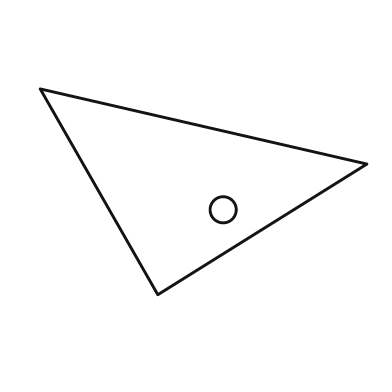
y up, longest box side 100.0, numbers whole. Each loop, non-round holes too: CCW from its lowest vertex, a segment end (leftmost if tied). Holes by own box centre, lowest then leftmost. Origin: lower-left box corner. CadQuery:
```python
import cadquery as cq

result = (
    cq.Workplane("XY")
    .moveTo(36.0, 0.0)
    .lineTo(100.0, 40.0)
    .lineTo(0.0, 63.0)
    .close()
    .moveTo(56.0, 26.0)
    .circle(4.0)
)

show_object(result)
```